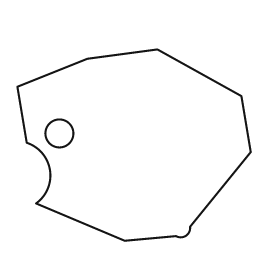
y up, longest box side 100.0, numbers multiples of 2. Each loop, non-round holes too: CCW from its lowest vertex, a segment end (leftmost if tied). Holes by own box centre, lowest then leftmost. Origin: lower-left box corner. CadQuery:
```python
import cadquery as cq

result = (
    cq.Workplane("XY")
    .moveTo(46.0, 0.0)
    .lineTo(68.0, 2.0)
    .threePointArc((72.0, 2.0), (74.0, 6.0))
    .lineTo(100.0, 38.0)
    .lineTo(96.0, 62.0)
    .lineTo(60.0, 82.0)
    .lineTo(30.0, 78.0)
    .lineTo(0.0, 66.0)
    .lineTo(4.0, 42.0)
    .threePointArc((14.0, 30.0), (8.0, 16.0))
    .close()
    .moveTo(18.0, 46.0)
    .circle(6.0)
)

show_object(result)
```